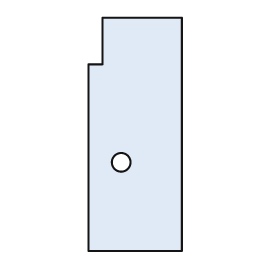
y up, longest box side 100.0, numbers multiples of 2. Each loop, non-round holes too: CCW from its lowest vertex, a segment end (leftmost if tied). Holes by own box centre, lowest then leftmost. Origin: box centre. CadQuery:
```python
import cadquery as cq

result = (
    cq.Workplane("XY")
    .moveTo(-20.0, -50.0)
    .lineTo(20.0, -50.0)
    .lineTo(20.0, 50.0)
    .lineTo(-14.0, 50.0)
    .lineTo(-14.0, 30.0)
    .lineTo(-20.0, 30.0)
    .close()
    .moveTo(-6.0, -12.0)
    .circle(4.0)
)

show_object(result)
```